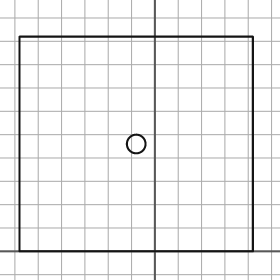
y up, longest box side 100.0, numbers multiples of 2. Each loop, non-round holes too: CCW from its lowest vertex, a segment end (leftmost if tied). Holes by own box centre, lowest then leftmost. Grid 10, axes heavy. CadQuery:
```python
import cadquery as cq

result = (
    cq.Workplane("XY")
    .moveTo(-58.0, 0.0)
    .lineTo(42.0, 0.0)
    .lineTo(42.0, 92.0)
    .lineTo(-58.0, 92.0)
    .close()
    .moveTo(-8.0, 46.0)
    .circle(4.0)
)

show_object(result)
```